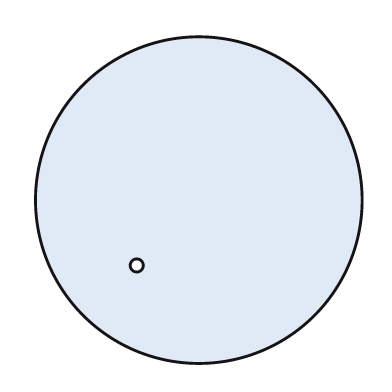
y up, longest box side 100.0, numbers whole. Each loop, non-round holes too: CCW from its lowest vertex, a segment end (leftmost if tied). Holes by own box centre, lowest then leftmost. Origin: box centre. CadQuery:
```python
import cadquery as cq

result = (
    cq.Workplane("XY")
    .moveTo(0.0, 0.0)
    .circle(50.0)
    .moveTo(-19.0, -20.0)
    .circle(2.0)
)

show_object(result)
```